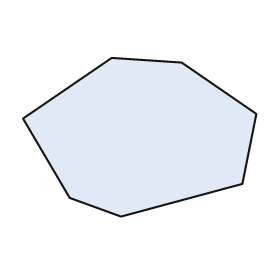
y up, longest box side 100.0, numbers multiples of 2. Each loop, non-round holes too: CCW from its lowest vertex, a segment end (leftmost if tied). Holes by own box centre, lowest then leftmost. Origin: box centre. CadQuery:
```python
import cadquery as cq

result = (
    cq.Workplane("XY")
    .moveTo(-8.0, -34.0)
    .lineTo(44.0, -20.0)
    .lineTo(50.0, 10.0)
    .lineTo(18.0, 32.0)
    .lineTo(-12.0, 34.0)
    .lineTo(-50.0, 8.0)
    .lineTo(-30.0, -26.0)
    .close()
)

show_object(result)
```